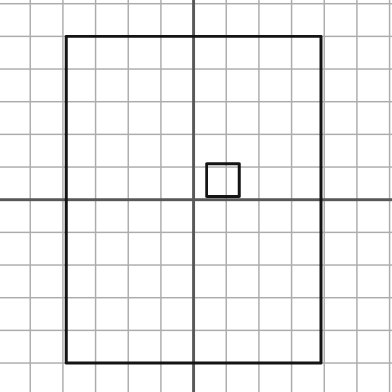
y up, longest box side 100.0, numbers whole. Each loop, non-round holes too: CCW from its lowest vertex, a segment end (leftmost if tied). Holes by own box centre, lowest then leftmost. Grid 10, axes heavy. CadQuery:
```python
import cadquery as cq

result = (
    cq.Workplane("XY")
    .moveTo(-39.0, -50.0)
    .lineTo(39.0, -50.0)
    .lineTo(39.0, 50.0)
    .lineTo(-39.0, 50.0)
    .close()
    .moveTo(4.0, 1.0)
    .lineTo(14.0, 1.0)
    .lineTo(14.0, 11.0)
    .lineTo(4.0, 11.0)
    .close()
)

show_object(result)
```